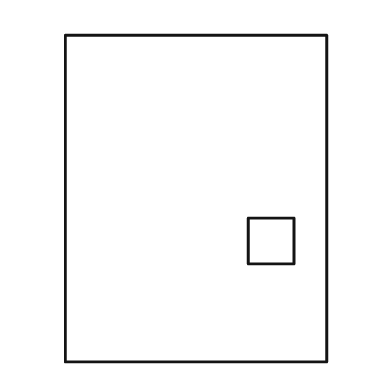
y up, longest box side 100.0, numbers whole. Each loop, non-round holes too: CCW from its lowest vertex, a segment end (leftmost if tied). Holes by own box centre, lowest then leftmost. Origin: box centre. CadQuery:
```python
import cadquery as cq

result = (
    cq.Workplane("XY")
    .moveTo(-40.0, -50.0)
    .lineTo(40.0, -50.0)
    .lineTo(40.0, 50.0)
    .lineTo(-40.0, 50.0)
    .close()
    .moveTo(16.0, -20.0)
    .lineTo(30.0, -20.0)
    .lineTo(30.0, -6.0)
    .lineTo(16.0, -6.0)
    .close()
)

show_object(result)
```